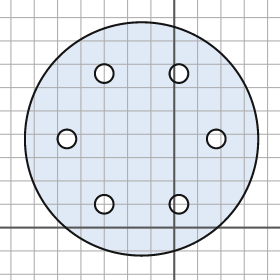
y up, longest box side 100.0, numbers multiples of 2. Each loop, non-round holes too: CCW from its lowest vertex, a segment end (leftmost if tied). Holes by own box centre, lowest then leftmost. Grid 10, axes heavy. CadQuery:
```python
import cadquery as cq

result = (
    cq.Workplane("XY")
    .moveTo(-14.0, 38.0)
    .circle(50.0)
    .moveTo(-30.0, 10.0)
    .circle(4.0)
    .moveTo(2.0, 10.0)
    .circle(4.0)
    .moveTo(-46.0, 38.0)
    .circle(4.0)
    .moveTo(18.0, 38.0)
    .circle(4.0)
    .moveTo(-30.0, 66.0)
    .circle(4.0)
    .moveTo(2.0, 66.0)
    .circle(4.0)
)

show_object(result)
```